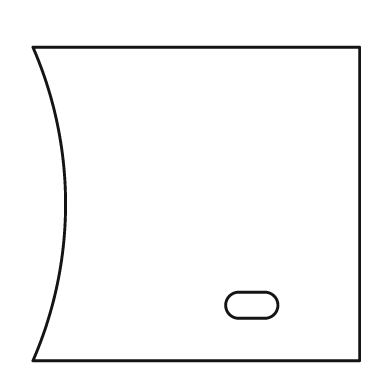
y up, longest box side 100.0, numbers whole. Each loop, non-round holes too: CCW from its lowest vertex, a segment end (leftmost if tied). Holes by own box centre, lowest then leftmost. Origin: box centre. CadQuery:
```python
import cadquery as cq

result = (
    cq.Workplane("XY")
    .moveTo(-50.0, -48.0)
    .lineTo(50.0, -48.0)
    .lineTo(50.0, 48.0)
    .lineTo(-50.0, 48.0)
    .threePointArc((-40.0, 0.0), (-50.0, -48.0))
    .close()
    .moveTo(13.0, -35.0)
    .lineTo(21.0, -35.0)
    .threePointArc((25.0, -31.0), (21.0, -27.0))
    .lineTo(13.0, -27.0)
    .threePointArc((9.0, -31.0), (13.0, -35.0))
    .close()
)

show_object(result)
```